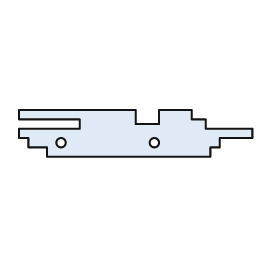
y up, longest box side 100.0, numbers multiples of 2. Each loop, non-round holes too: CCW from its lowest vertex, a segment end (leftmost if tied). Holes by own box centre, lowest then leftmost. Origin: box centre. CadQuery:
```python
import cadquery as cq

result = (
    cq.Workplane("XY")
    .moveTo(-38.0, -10.0)
    .lineTo(32.0, -10.0)
    .lineTo(32.0, -6.0)
    .lineTo(36.0, -6.0)
    .lineTo(36.0, -2.0)
    .lineTo(50.0, -2.0)
    .lineTo(50.0, 2.0)
    .lineTo(30.0, 2.0)
    .lineTo(30.0, 6.0)
    .lineTo(24.0, 6.0)
    .lineTo(24.0, 10.0)
    .lineTo(10.0, 10.0)
    .lineTo(10.0, 4.0)
    .lineTo(0.0, 4.0)
    .lineTo(0.0, 10.0)
    .lineTo(-50.0, 10.0)
    .lineTo(-50.0, 6.0)
    .lineTo(-24.0, 6.0)
    .lineTo(-24.0, 2.0)
    .lineTo(-50.0, 2.0)
    .lineTo(-50.0, -2.0)
    .lineTo(-46.0, -2.0)
    .lineTo(-46.0, -6.0)
    .lineTo(-38.0, -6.0)
    .close()
    .moveTo(-32.0, -4.0)
    .circle(2.0)
    .moveTo(8.0, -4.0)
    .circle(2.0)
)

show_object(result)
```